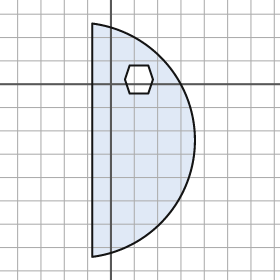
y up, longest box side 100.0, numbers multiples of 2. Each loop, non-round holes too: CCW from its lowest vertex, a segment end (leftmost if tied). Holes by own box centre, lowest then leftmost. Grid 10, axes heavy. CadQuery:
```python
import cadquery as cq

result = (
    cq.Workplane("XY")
    .moveTo(-8.0, -74.0)
    .threePointArc((36.0, -24.0), (-8.0, 26.0))
    .close()
    .moveTo(8.0, -4.0)
    .lineTo(16.0, -4.0)
    .lineTo(18.0, 2.0)
    .lineTo(16.0, 8.0)
    .lineTo(8.0, 8.0)
    .lineTo(6.0, 2.0)
    .close()
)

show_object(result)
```